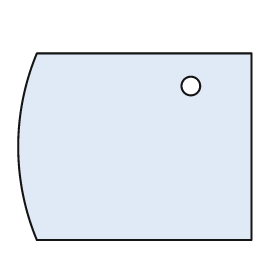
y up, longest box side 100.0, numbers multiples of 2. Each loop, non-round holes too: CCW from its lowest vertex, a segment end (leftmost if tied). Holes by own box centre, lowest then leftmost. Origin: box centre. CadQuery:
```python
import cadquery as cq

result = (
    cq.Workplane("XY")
    .moveTo(-42.0, -40.0)
    .lineTo(50.0, -40.0)
    .lineTo(50.0, 40.0)
    .lineTo(-42.0, 40.0)
    .threePointArc((-50.0, 0.0), (-42.0, -40.0))
    .close()
    .moveTo(24.0, 26.0)
    .circle(4.0)
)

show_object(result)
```